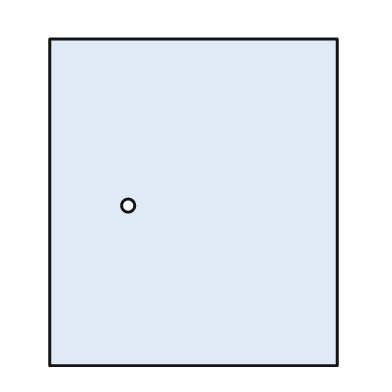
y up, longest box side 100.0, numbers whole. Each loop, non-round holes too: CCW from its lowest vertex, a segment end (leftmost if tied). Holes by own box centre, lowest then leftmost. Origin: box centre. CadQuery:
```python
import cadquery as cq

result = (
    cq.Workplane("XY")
    .moveTo(-44.0, -50.0)
    .lineTo(44.0, -50.0)
    .lineTo(44.0, 50.0)
    .lineTo(-44.0, 50.0)
    .close()
    .moveTo(-20.0, -1.0)
    .circle(2.0)
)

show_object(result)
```